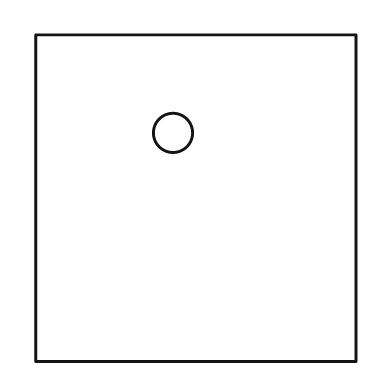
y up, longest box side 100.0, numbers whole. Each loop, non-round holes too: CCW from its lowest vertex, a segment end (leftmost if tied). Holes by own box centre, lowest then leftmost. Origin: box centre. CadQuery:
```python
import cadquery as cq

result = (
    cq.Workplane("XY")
    .moveTo(-49.0, -50.0)
    .lineTo(49.0, -50.0)
    .lineTo(49.0, 50.0)
    .lineTo(-49.0, 50.0)
    .close()
    .moveTo(-7.0, 20.0)
    .circle(6.0)
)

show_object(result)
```